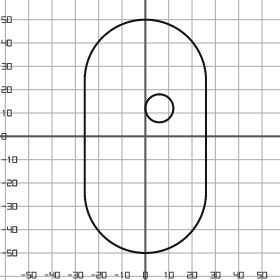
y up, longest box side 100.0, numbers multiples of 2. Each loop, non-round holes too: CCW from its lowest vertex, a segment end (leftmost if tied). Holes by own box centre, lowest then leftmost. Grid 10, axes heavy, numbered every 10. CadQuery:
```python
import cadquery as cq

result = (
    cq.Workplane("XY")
    .moveTo(-26.0, -24.0)
    .threePointArc((0.0, -50.0), (26.0, -24.0))
    .lineTo(26.0, 24.0)
    .threePointArc((0.0, 50.0), (-26.0, 24.0))
    .close()
    .moveTo(6.0, 12.0)
    .circle(6.0)
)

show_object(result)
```